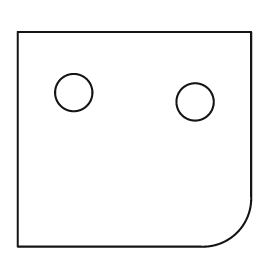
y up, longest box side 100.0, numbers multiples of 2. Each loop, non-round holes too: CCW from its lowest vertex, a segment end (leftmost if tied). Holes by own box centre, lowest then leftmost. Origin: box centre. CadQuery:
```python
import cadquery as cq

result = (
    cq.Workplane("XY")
    .moveTo(-50.0, -46.0)
    .lineTo(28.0, -46.0)
    .threePointArc((44.0, -40.0), (50.0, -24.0))
    .lineTo(50.0, 46.0)
    .lineTo(-50.0, 46.0)
    .close()
    .moveTo(26.0, 16.0)
    .circle(8.0)
    .moveTo(-26.0, 20.0)
    .circle(8.0)
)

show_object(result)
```